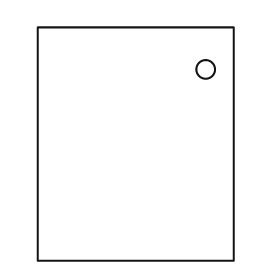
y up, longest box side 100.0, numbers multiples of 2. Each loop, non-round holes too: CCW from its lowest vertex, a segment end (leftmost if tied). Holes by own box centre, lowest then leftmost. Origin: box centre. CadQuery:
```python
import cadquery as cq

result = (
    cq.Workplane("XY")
    .moveTo(-42.0, -50.0)
    .lineTo(42.0, -50.0)
    .lineTo(42.0, 50.0)
    .lineTo(-42.0, 50.0)
    .close()
    .moveTo(30.0, 32.0)
    .circle(4.0)
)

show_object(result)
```